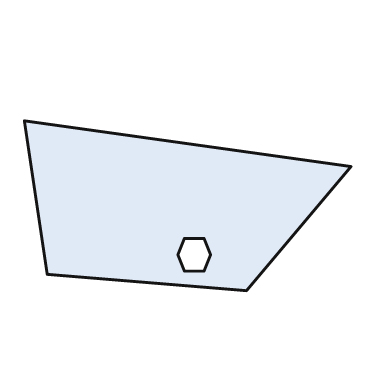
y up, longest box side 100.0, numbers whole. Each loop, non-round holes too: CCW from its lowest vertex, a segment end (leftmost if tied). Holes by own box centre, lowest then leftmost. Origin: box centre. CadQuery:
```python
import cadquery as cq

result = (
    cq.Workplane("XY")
    .moveTo(18.0, -26.0)
    .lineTo(50.0, 12.0)
    .lineTo(-50.0, 26.0)
    .lineTo(-43.0, -21.0)
    .close()
    .moveTo(-1.0, -20.0)
    .lineTo(5.0, -20.0)
    .lineTo(7.0, -15.0)
    .lineTo(5.0, -10.0)
    .lineTo(-1.0, -10.0)
    .lineTo(-3.0, -15.0)
    .close()
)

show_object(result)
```